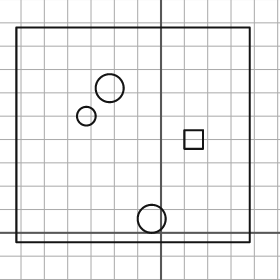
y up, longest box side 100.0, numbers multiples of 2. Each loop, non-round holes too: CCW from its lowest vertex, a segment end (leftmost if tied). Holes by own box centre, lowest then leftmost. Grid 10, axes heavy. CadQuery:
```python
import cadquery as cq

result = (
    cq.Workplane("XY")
    .moveTo(-62.0, -4.0)
    .lineTo(38.0, -4.0)
    .lineTo(38.0, 88.0)
    .lineTo(-62.0, 88.0)
    .close()
    .moveTo(-4.0, 6.0)
    .circle(6.0)
    .moveTo(10.0, 36.0)
    .lineTo(18.0, 36.0)
    .lineTo(18.0, 44.0)
    .lineTo(10.0, 44.0)
    .close()
    .moveTo(-32.0, 50.0)
    .circle(4.0)
    .moveTo(-22.0, 62.0)
    .circle(6.0)
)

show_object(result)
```